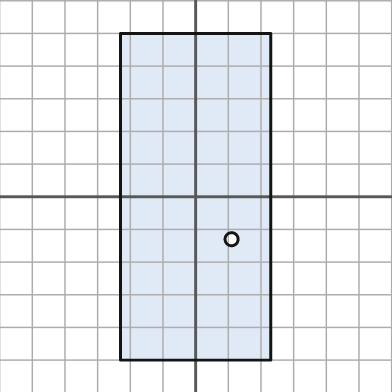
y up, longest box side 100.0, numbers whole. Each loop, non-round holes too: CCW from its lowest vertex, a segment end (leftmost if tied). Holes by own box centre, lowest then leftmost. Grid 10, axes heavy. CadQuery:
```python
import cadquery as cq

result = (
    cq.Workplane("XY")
    .moveTo(-23.0, -50.0)
    .lineTo(23.0, -50.0)
    .lineTo(23.0, 50.0)
    .lineTo(-23.0, 50.0)
    .close()
    .moveTo(11.0, -13.0)
    .circle(2.0)
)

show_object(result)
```